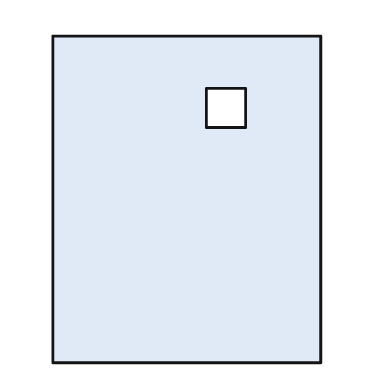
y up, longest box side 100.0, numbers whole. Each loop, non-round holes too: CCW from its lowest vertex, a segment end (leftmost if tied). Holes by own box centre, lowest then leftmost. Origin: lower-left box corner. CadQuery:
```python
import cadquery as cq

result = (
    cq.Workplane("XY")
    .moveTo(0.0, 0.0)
    .lineTo(82.0, 0.0)
    .lineTo(82.0, 100.0)
    .lineTo(0.0, 100.0)
    .close()
    .moveTo(47.0, 72.0)
    .lineTo(59.0, 72.0)
    .lineTo(59.0, 84.0)
    .lineTo(47.0, 84.0)
    .close()
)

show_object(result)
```